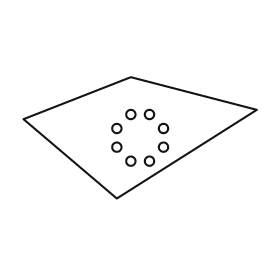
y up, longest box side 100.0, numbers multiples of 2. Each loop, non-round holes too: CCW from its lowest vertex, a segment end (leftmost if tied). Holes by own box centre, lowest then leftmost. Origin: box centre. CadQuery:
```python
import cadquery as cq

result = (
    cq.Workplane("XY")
    .moveTo(-10.0, -26.0)
    .lineTo(50.0, 12.0)
    .lineTo(-4.0, 26.0)
    .lineTo(-50.0, 8.0)
    .close()
    .moveTo(-4.0, -10.0)
    .circle(2.0)
    .moveTo(4.0, -10.0)
    .circle(2.0)
    .moveTo(-10.0, -4.0)
    .circle(2.0)
    .moveTo(10.0, -4.0)
    .circle(2.0)
    .moveTo(-10.0, 4.0)
    .circle(2.0)
    .moveTo(10.0, 4.0)
    .circle(2.0)
    .moveTo(-4.0, 10.0)
    .circle(2.0)
    .moveTo(4.0, 10.0)
    .circle(2.0)
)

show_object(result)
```